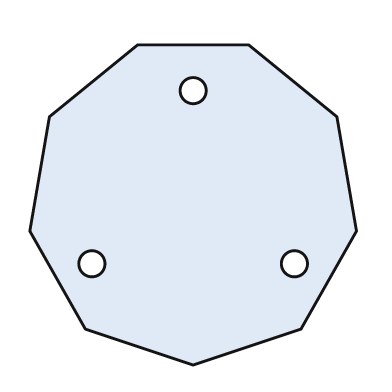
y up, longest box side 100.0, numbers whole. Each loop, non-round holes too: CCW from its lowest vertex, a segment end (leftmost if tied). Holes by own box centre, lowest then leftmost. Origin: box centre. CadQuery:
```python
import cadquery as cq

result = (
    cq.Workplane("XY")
    .moveTo(0.0, -49.0)
    .lineTo(33.0, -38.0)
    .lineTo(50.0, -8.0)
    .lineTo(44.0, 27.0)
    .lineTo(17.0, 49.0)
    .lineTo(-17.0, 49.0)
    .lineTo(-44.0, 27.0)
    .lineTo(-50.0, -8.0)
    .lineTo(-33.0, -38.0)
    .close()
    .moveTo(-31.0, -18.0)
    .circle(4.0)
    .moveTo(31.0, -18.0)
    .circle(4.0)
    .moveTo(0.0, 35.0)
    .circle(4.0)
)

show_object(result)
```